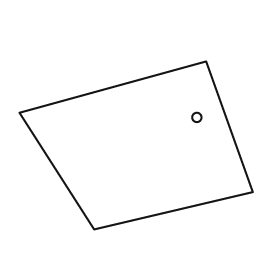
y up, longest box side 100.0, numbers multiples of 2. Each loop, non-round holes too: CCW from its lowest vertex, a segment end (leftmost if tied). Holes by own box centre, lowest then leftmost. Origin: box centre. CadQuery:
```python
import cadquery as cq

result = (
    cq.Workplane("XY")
    .moveTo(-18.0, -36.0)
    .lineTo(50.0, -20.0)
    .lineTo(30.0, 36.0)
    .lineTo(-50.0, 14.0)
    .close()
    .moveTo(26.0, 12.0)
    .circle(2.0)
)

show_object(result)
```